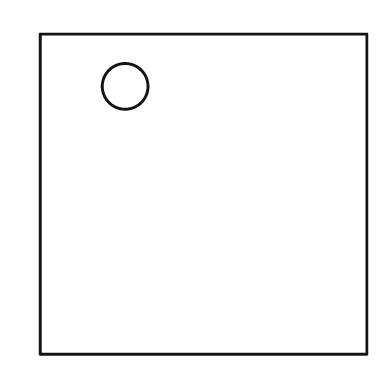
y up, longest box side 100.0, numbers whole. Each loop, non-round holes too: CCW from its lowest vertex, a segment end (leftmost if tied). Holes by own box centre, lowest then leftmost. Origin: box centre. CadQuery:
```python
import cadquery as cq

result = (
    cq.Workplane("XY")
    .moveTo(-50.0, -49.0)
    .lineTo(50.0, -49.0)
    .lineTo(50.0, 49.0)
    .lineTo(-50.0, 49.0)
    .close()
    .moveTo(-24.0, 33.0)
    .circle(7.0)
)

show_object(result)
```